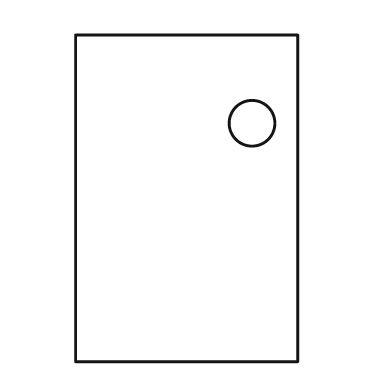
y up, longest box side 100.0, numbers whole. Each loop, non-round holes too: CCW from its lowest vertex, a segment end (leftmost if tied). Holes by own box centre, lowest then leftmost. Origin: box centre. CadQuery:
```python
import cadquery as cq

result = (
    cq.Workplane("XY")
    .moveTo(-34.0, -50.0)
    .lineTo(34.0, -50.0)
    .lineTo(34.0, 50.0)
    .lineTo(-34.0, 50.0)
    .close()
    .moveTo(20.0, 23.0)
    .circle(7.0)
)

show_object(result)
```